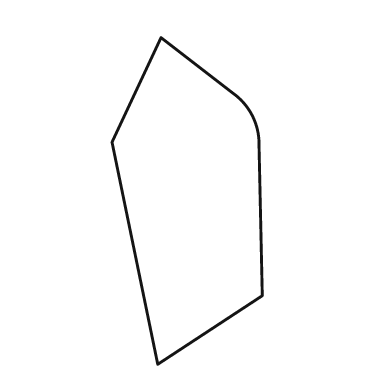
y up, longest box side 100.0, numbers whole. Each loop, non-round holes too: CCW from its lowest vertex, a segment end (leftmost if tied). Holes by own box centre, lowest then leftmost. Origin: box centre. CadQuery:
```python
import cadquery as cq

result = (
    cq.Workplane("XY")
    .moveTo(-9.0, -50.0)
    .lineTo(23.0, -29.0)
    .lineTo(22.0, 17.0)
    .threePointArc((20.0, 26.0), (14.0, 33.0))
    .lineTo(-8.0, 50.0)
    .lineTo(-23.0, 18.0)
    .close()
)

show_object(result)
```